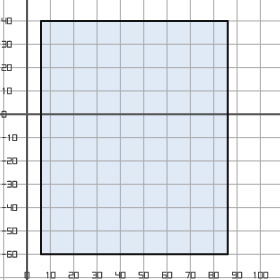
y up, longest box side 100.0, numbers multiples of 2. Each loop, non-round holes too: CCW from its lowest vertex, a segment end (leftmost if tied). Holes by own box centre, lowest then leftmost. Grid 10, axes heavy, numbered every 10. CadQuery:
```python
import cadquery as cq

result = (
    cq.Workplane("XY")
    .moveTo(6.0, -60.0)
    .lineTo(86.0, -60.0)
    .lineTo(86.0, 40.0)
    .lineTo(6.0, 40.0)
    .close()
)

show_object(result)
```